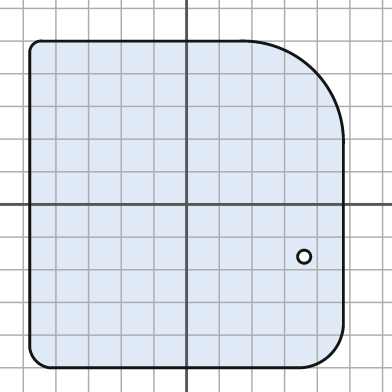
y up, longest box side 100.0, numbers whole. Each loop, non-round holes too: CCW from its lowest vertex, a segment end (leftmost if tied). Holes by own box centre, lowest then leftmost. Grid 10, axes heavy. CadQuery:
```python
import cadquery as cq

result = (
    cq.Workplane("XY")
    .moveTo(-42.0, -50.0)
    .lineTo(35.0, -50.0)
    .threePointArc((44.0, -46.0), (48.0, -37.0))
    .lineTo(48.0, 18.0)
    .threePointArc((39.0, 41.0), (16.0, 50.0))
    .lineTo(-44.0, 50.0)
    .threePointArc((-47.0, 49.0), (-48.0, 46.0))
    .lineTo(-48.0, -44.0)
    .threePointArc((-46.0, -48.0), (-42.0, -50.0))
    .close()
    .moveTo(36.0, -16.0)
    .circle(2.0)
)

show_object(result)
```